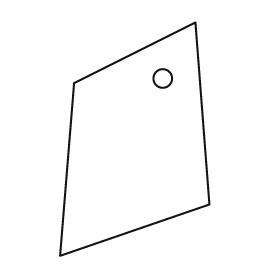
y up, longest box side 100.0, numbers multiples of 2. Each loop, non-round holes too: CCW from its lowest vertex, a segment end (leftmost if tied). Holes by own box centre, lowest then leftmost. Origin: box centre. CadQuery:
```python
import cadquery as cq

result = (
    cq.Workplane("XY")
    .moveTo(-32.0, -50.0)
    .lineTo(32.0, -28.0)
    .lineTo(26.0, 50.0)
    .lineTo(-26.0, 24.0)
    .close()
    .moveTo(12.0, 26.0)
    .circle(4.0)
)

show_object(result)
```